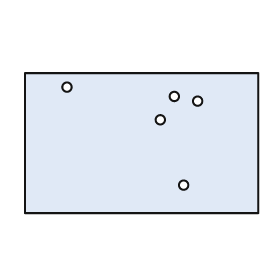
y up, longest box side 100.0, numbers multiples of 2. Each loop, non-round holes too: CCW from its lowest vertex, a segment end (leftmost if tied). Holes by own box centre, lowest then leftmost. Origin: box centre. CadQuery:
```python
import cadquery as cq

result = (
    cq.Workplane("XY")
    .moveTo(-50.0, -30.0)
    .lineTo(50.0, -30.0)
    .lineTo(50.0, 30.0)
    .lineTo(-50.0, 30.0)
    .close()
    .moveTo(18.0, -18.0)
    .circle(2.0)
    .moveTo(8.0, 10.0)
    .circle(2.0)
    .moveTo(24.0, 18.0)
    .circle(2.0)
    .moveTo(14.0, 20.0)
    .circle(2.0)
    .moveTo(-32.0, 24.0)
    .circle(2.0)
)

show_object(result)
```